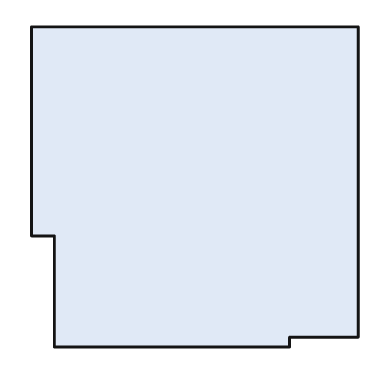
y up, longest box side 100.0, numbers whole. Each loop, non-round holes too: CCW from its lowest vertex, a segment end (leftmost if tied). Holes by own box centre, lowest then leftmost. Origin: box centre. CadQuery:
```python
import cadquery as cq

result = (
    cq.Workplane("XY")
    .moveTo(-43.0, -49.0)
    .lineTo(29.0, -49.0)
    .lineTo(29.0, -46.0)
    .lineTo(50.0, -46.0)
    .lineTo(50.0, 49.0)
    .lineTo(-50.0, 49.0)
    .lineTo(-50.0, -15.0)
    .lineTo(-43.0, -15.0)
    .close()
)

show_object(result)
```